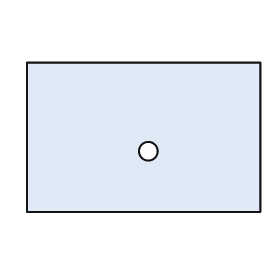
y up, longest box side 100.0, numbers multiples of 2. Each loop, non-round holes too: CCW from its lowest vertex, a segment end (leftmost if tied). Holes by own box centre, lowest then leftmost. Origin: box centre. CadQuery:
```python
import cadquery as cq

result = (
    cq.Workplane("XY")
    .moveTo(-50.0, -32.0)
    .lineTo(50.0, -32.0)
    .lineTo(50.0, 32.0)
    .lineTo(-50.0, 32.0)
    .close()
    .moveTo(2.0, -6.0)
    .circle(4.0)
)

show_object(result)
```